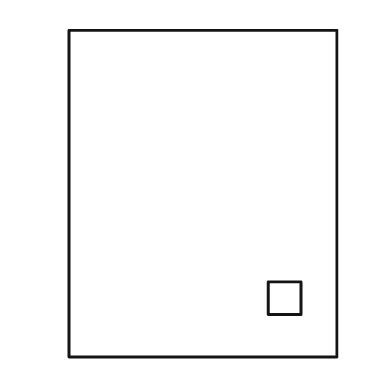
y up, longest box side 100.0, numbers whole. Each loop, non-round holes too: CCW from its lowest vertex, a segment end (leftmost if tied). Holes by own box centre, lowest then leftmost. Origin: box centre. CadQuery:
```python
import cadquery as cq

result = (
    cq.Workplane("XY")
    .moveTo(-41.0, -50.0)
    .lineTo(41.0, -50.0)
    .lineTo(41.0, 50.0)
    .lineTo(-41.0, 50.0)
    .close()
    .moveTo(20.0, -37.0)
    .lineTo(30.0, -37.0)
    .lineTo(30.0, -27.0)
    .lineTo(20.0, -27.0)
    .close()
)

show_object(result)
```